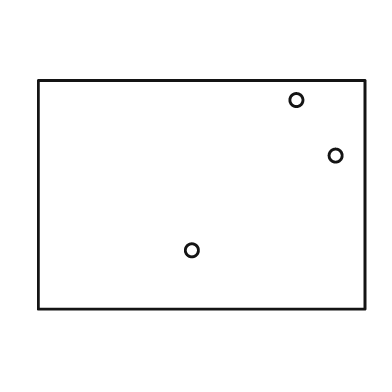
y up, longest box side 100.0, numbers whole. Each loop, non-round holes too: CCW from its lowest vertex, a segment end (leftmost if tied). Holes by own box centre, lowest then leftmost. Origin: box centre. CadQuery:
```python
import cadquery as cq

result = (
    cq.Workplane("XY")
    .moveTo(-50.0, -35.0)
    .lineTo(50.0, -35.0)
    .lineTo(50.0, 35.0)
    .lineTo(-50.0, 35.0)
    .close()
    .moveTo(-3.0, -17.0)
    .circle(2.0)
    .moveTo(41.0, 12.0)
    .circle(2.0)
    .moveTo(29.0, 29.0)
    .circle(2.0)
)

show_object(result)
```